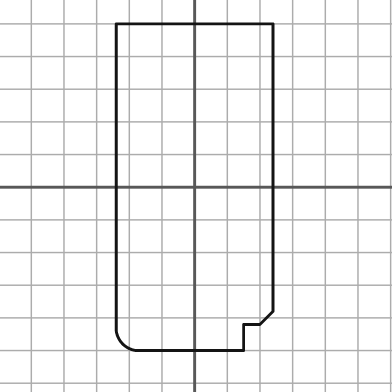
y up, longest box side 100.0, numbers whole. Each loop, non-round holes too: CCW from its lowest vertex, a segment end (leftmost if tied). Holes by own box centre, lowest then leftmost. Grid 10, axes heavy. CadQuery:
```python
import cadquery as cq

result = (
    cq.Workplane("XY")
    .moveTo(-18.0, -50.0)
    .lineTo(15.0, -50.0)
    .lineTo(15.0, -42.0)
    .lineTo(20.0, -42.0)
    .lineTo(24.0, -38.0)
    .lineTo(24.0, 50.0)
    .lineTo(-24.0, 50.0)
    .lineTo(-24.0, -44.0)
    .threePointArc((-22.0, -48.0), (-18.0, -50.0))
    .close()
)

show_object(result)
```